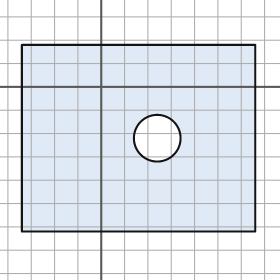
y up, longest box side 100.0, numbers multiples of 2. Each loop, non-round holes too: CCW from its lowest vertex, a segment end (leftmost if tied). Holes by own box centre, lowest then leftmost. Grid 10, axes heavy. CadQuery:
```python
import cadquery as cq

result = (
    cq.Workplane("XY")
    .moveTo(-34.0, -62.0)
    .lineTo(66.0, -62.0)
    .lineTo(66.0, 18.0)
    .lineTo(-34.0, 18.0)
    .close()
    .moveTo(24.0, -22.0)
    .circle(10.0)
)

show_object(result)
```